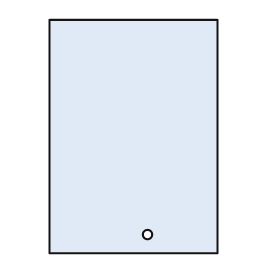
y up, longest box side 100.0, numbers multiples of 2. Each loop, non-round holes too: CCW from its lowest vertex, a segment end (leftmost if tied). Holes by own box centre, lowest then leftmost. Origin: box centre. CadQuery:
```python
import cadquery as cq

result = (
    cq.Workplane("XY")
    .moveTo(-36.0, -50.0)
    .lineTo(36.0, -50.0)
    .lineTo(36.0, 50.0)
    .lineTo(-36.0, 50.0)
    .close()
    .moveTo(6.0, -42.0)
    .circle(2.0)
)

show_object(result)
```